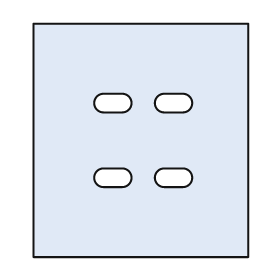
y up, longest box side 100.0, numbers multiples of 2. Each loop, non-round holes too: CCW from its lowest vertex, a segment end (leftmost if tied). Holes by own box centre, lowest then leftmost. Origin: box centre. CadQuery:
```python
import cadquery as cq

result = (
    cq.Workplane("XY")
    .moveTo(-46.0, -50.0)
    .lineTo(46.0, -50.0)
    .lineTo(46.0, 50.0)
    .lineTo(-46.0, 50.0)
    .close()
    .moveTo(-16.0, -20.0)
    .lineTo(-8.0, -20.0)
    .threePointArc((-4.0, -16.0), (-8.0, -12.0))
    .lineTo(-16.0, -12.0)
    .threePointArc((-20.0, -16.0), (-16.0, -20.0))
    .close()
    .moveTo(10.0, -20.0)
    .lineTo(18.0, -20.0)
    .threePointArc((22.0, -16.0), (18.0, -12.0))
    .lineTo(10.0, -12.0)
    .threePointArc((6.0, -16.0), (10.0, -20.0))
    .close()
    .moveTo(-16.0, 12.0)
    .lineTo(-8.0, 12.0)
    .threePointArc((-4.0, 16.0), (-8.0, 20.0))
    .lineTo(-16.0, 20.0)
    .threePointArc((-20.0, 16.0), (-16.0, 12.0))
    .close()
    .moveTo(10.0, 12.0)
    .lineTo(18.0, 12.0)
    .threePointArc((22.0, 16.0), (18.0, 20.0))
    .lineTo(10.0, 20.0)
    .threePointArc((6.0, 16.0), (10.0, 12.0))
    .close()
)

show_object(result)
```